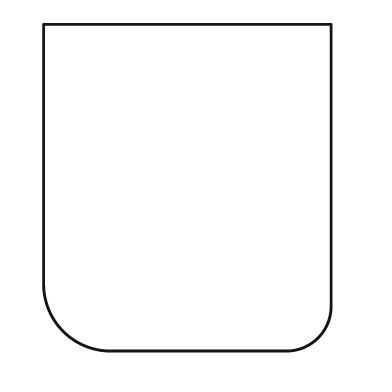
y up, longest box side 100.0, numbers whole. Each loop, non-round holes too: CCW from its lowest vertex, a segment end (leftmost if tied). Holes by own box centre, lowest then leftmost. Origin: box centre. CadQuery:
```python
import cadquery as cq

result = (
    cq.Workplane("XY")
    .moveTo(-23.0, -50.0)
    .lineTo(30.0, -50.0)
    .threePointArc((40.0, -46.0), (44.0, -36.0))
    .lineTo(44.0, 50.0)
    .lineTo(-44.0, 50.0)
    .lineTo(-44.0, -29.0)
    .threePointArc((-38.0, -44.0), (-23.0, -50.0))
    .close()
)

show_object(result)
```